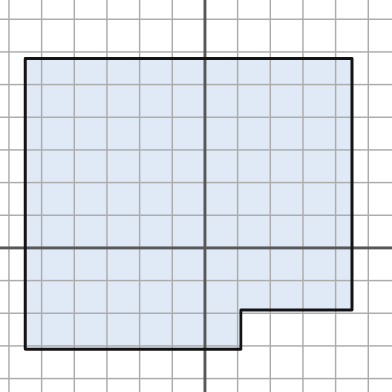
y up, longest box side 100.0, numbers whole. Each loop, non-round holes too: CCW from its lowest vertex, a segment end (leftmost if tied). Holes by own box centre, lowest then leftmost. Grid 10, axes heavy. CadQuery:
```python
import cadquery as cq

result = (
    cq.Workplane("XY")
    .moveTo(-55.0, -31.0)
    .lineTo(11.0, -31.0)
    .lineTo(11.0, -19.0)
    .lineTo(45.0, -19.0)
    .lineTo(45.0, 58.0)
    .lineTo(-55.0, 58.0)
    .close()
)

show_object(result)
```